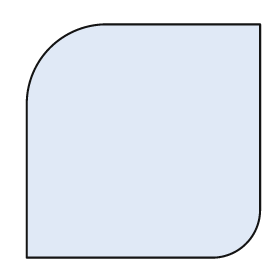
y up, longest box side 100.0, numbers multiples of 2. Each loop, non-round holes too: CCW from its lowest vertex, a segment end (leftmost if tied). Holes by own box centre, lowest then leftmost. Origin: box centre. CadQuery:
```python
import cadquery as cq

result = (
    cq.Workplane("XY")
    .moveTo(-50.0, -50.0)
    .lineTo(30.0, -50.0)
    .threePointArc((44.0, -44.0), (50.0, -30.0))
    .lineTo(50.0, 50.0)
    .lineTo(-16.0, 50.0)
    .threePointArc((-40.0, 40.0), (-50.0, 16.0))
    .close()
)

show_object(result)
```